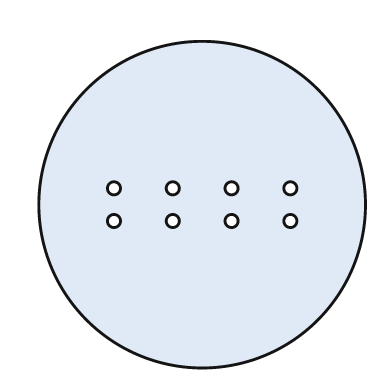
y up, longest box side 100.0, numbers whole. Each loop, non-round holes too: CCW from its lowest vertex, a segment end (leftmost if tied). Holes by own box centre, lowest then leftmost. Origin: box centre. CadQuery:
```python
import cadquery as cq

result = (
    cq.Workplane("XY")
    .moveTo(0.0, 0.0)
    .circle(50.0)
    .moveTo(-27.0, -5.0)
    .circle(2.0)
    .moveTo(-9.0, -5.0)
    .circle(2.0)
    .moveTo(9.0, -5.0)
    .circle(2.0)
    .moveTo(27.0, -5.0)
    .circle(2.0)
    .moveTo(-27.0, 5.0)
    .circle(2.0)
    .moveTo(-9.0, 5.0)
    .circle(2.0)
    .moveTo(9.0, 5.0)
    .circle(2.0)
    .moveTo(27.0, 5.0)
    .circle(2.0)
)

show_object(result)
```